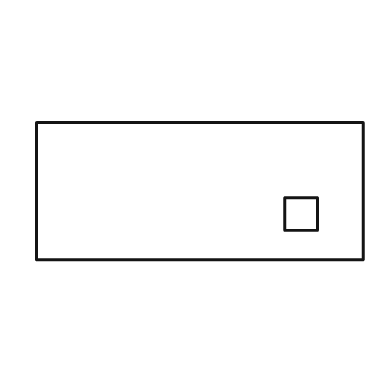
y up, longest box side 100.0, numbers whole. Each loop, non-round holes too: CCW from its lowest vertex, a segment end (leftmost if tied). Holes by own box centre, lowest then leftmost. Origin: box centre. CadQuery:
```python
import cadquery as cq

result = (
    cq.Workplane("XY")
    .moveTo(-50.0, -21.0)
    .lineTo(50.0, -21.0)
    .lineTo(50.0, 21.0)
    .lineTo(-50.0, 21.0)
    .close()
    .moveTo(26.0, -12.0)
    .lineTo(36.0, -12.0)
    .lineTo(36.0, -2.0)
    .lineTo(26.0, -2.0)
    .close()
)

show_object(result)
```